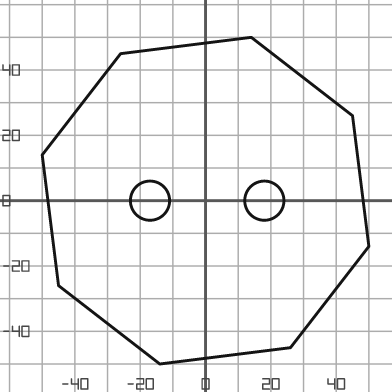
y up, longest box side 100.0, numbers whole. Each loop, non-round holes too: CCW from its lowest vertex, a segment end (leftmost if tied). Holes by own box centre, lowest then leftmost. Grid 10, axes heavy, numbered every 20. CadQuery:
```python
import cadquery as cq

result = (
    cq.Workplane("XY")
    .moveTo(-14.0, -50.0)
    .lineTo(26.0, -45.0)
    .lineTo(50.0, -14.0)
    .lineTo(45.0, 26.0)
    .lineTo(14.0, 50.0)
    .lineTo(-26.0, 45.0)
    .lineTo(-50.0, 14.0)
    .lineTo(-45.0, -26.0)
    .close()
    .moveTo(-17.0, 0.0)
    .circle(6.0)
    .moveTo(18.0, 0.0)
    .circle(6.0)
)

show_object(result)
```